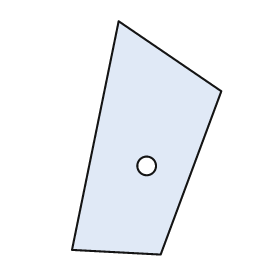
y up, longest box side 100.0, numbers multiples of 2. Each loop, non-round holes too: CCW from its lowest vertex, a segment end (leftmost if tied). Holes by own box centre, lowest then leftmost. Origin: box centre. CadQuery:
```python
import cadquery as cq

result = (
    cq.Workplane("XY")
    .moveTo(6.0, -50.0)
    .lineTo(32.0, 20.0)
    .lineTo(-12.0, 50.0)
    .lineTo(-32.0, -48.0)
    .close()
    .moveTo(0.0, -12.0)
    .circle(4.0)
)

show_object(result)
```